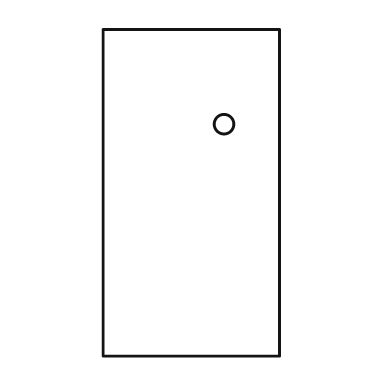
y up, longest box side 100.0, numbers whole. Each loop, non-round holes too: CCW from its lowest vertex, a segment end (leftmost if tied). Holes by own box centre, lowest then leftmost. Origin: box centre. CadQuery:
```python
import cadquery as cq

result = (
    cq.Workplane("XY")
    .moveTo(-27.0, -50.0)
    .lineTo(27.0, -50.0)
    .lineTo(27.0, 50.0)
    .lineTo(-27.0, 50.0)
    .close()
    .moveTo(10.0, 21.0)
    .circle(3.0)
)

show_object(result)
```